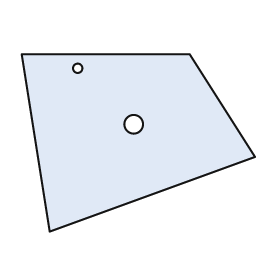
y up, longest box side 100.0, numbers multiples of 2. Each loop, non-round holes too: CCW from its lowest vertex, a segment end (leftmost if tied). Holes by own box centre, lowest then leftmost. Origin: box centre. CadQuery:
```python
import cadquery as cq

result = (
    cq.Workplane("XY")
    .moveTo(-38.0, -38.0)
    .lineTo(50.0, -6.0)
    .lineTo(22.0, 38.0)
    .lineTo(-50.0, 38.0)
    .close()
    .moveTo(-2.0, 8.0)
    .circle(4.0)
    .moveTo(-26.0, 32.0)
    .circle(2.0)
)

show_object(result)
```